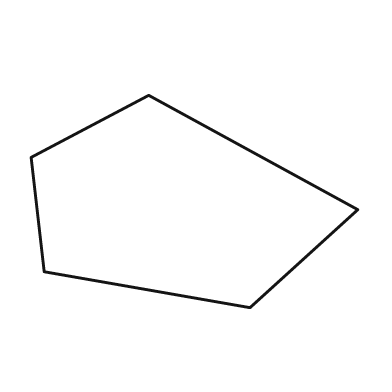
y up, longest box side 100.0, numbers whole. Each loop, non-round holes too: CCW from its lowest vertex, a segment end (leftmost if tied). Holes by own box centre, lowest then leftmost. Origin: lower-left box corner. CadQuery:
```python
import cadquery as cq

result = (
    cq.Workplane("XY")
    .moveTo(67.0, 0.0)
    .lineTo(100.0, 30.0)
    .lineTo(36.0, 65.0)
    .lineTo(0.0, 46.0)
    .lineTo(4.0, 11.0)
    .close()
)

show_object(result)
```